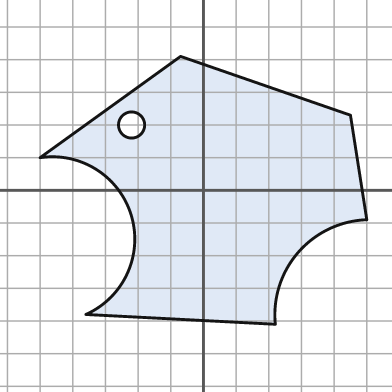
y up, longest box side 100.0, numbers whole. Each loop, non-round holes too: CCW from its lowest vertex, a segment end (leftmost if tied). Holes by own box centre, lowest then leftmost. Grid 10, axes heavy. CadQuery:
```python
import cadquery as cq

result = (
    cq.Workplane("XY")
    .moveTo(22.0, -41.0)
    .threePointArc((29.0, -19.0), (50.0, -9.0))
    .lineTo(45.0, 23.0)
    .lineTo(-7.0, 41.0)
    .lineTo(-50.0, 10.0)
    .threePointArc((-22.0, -8.0), (-36.0, -38.0))
    .close()
    .moveTo(-22.0, 20.0)
    .circle(4.0)
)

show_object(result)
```